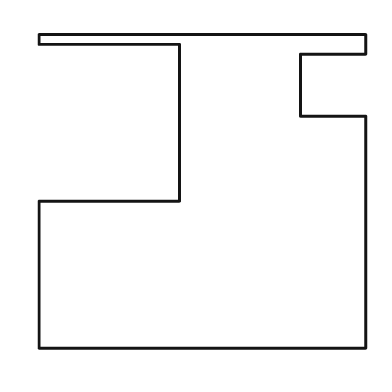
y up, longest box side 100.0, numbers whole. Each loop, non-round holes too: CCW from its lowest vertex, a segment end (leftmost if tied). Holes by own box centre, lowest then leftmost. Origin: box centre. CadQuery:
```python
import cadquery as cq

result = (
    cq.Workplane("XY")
    .moveTo(-50.0, -48.0)
    .lineTo(50.0, -48.0)
    .lineTo(50.0, 23.0)
    .lineTo(30.0, 23.0)
    .lineTo(30.0, 42.0)
    .lineTo(50.0, 42.0)
    .lineTo(50.0, 48.0)
    .lineTo(-50.0, 48.0)
    .lineTo(-50.0, 45.0)
    .lineTo(-7.0, 45.0)
    .lineTo(-7.0, -3.0)
    .lineTo(-50.0, -3.0)
    .close()
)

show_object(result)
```